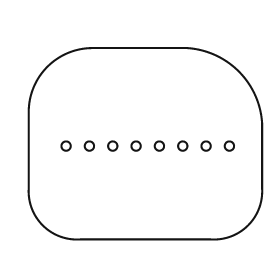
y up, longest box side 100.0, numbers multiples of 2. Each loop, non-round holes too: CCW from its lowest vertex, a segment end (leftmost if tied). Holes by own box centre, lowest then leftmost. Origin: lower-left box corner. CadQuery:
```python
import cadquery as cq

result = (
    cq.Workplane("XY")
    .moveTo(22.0, 0.0)
    .lineTo(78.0, 0.0)
    .threePointArc((94.0, 6.0), (100.0, 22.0))
    .lineTo(100.0, 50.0)
    .threePointArc((90.0, 72.0), (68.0, 82.0))
    .lineTo(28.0, 82.0)
    .threePointArc((8.0, 74.0), (0.0, 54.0))
    .lineTo(0.0, 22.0)
    .threePointArc((6.0, 6.0), (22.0, 0.0))
    .close()
    .moveTo(16.0, 40.0)
    .circle(2.0)
    .moveTo(26.0, 40.0)
    .circle(2.0)
    .moveTo(36.0, 40.0)
    .circle(2.0)
    .moveTo(46.0, 40.0)
    .circle(2.0)
    .moveTo(56.0, 40.0)
    .circle(2.0)
    .moveTo(66.0, 40.0)
    .circle(2.0)
    .moveTo(76.0, 40.0)
    .circle(2.0)
    .moveTo(86.0, 40.0)
    .circle(2.0)
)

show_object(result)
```